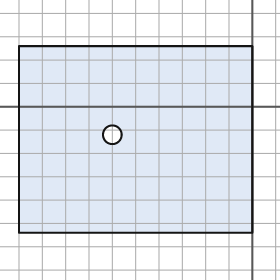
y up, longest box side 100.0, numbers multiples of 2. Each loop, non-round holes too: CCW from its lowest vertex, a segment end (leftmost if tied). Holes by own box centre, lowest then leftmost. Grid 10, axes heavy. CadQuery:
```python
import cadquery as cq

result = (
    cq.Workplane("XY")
    .moveTo(-100.0, -54.0)
    .lineTo(0.0, -54.0)
    .lineTo(0.0, 26.0)
    .lineTo(-100.0, 26.0)
    .close()
    .moveTo(-60.0, -12.0)
    .circle(4.0)
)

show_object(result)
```